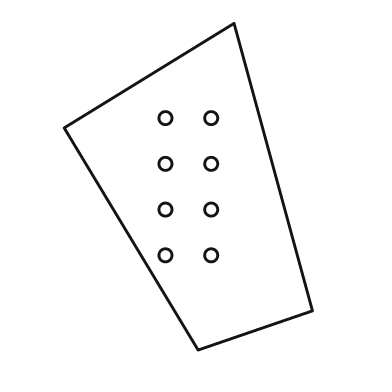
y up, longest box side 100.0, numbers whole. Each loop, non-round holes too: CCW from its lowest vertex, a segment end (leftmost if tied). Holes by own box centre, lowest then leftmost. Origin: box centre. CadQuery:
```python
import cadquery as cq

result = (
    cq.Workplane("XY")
    .moveTo(3.0, -50.0)
    .lineTo(38.0, -38.0)
    .lineTo(14.0, 50.0)
    .lineTo(-38.0, 18.0)
    .close()
    .moveTo(-7.0, -21.0)
    .circle(2.0)
    .moveTo(7.0, -21.0)
    .circle(2.0)
    .moveTo(-7.0, -7.0)
    .circle(2.0)
    .moveTo(7.0, -7.0)
    .circle(2.0)
    .moveTo(-7.0, 7.0)
    .circle(2.0)
    .moveTo(7.0, 7.0)
    .circle(2.0)
    .moveTo(-7.0, 21.0)
    .circle(2.0)
    .moveTo(7.0, 21.0)
    .circle(2.0)
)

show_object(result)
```